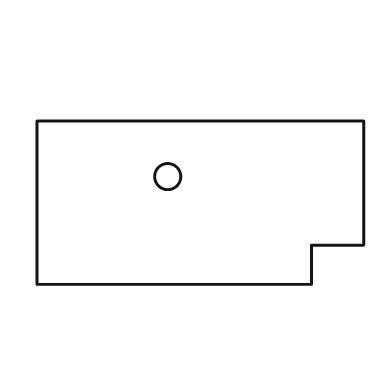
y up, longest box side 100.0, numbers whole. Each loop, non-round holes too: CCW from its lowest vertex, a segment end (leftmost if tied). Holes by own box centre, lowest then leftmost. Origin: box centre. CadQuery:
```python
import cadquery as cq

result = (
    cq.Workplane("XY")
    .moveTo(-50.0, -25.0)
    .lineTo(34.0, -25.0)
    .lineTo(34.0, -13.0)
    .lineTo(50.0, -13.0)
    .lineTo(50.0, 25.0)
    .lineTo(-50.0, 25.0)
    .close()
    .moveTo(-10.0, 8.0)
    .circle(4.0)
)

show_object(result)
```